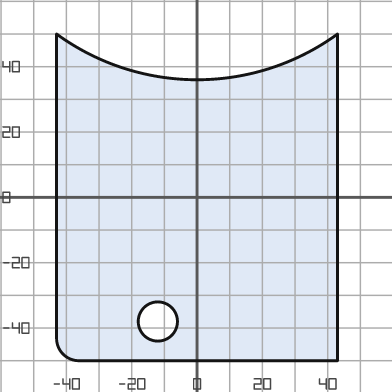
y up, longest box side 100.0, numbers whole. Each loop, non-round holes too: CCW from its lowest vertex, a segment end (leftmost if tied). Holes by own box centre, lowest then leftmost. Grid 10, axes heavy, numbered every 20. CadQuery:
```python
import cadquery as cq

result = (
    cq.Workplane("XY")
    .moveTo(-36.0, -50.0)
    .lineTo(43.0, -50.0)
    .lineTo(43.0, 50.0)
    .threePointArc((0.0, 36.0), (-43.0, 50.0))
    .lineTo(-43.0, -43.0)
    .threePointArc((-41.0, -48.0), (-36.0, -50.0))
    .close()
    .moveTo(-12.0, -38.0)
    .circle(6.0)
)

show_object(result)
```